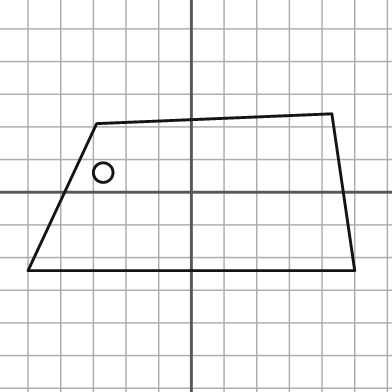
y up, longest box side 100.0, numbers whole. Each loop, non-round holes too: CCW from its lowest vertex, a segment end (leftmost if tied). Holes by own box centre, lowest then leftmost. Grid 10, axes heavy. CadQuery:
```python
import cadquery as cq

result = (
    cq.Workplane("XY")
    .moveTo(-50.0, -24.0)
    .lineTo(50.0, -24.0)
    .lineTo(43.0, 24.0)
    .lineTo(-29.0, 21.0)
    .close()
    .moveTo(-27.0, 6.0)
    .circle(3.0)
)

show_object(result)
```